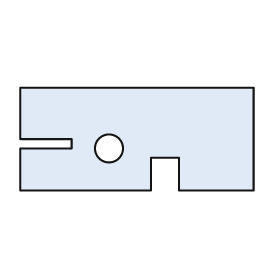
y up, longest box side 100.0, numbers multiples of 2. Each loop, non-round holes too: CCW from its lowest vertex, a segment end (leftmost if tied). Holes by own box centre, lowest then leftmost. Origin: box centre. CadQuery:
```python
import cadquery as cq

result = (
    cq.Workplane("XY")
    .moveTo(-50.0, -22.0)
    .lineTo(6.0, -22.0)
    .lineTo(6.0, -8.0)
    .lineTo(18.0, -8.0)
    .lineTo(18.0, -22.0)
    .lineTo(50.0, -22.0)
    .lineTo(50.0, 22.0)
    .lineTo(-50.0, 22.0)
    .lineTo(-50.0, 0.0)
    .lineTo(-28.0, 0.0)
    .lineTo(-28.0, -4.0)
    .lineTo(-50.0, -4.0)
    .close()
    .moveTo(-12.0, -4.0)
    .circle(6.0)
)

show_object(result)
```